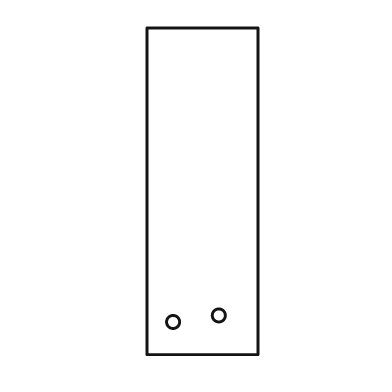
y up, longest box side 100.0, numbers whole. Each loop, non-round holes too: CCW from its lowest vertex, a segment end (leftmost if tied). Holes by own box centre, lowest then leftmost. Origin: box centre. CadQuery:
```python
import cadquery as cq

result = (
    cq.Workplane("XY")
    .moveTo(-17.0, -50.0)
    .lineTo(17.0, -50.0)
    .lineTo(17.0, 50.0)
    .lineTo(-17.0, 50.0)
    .close()
    .moveTo(-9.0, -40.0)
    .circle(2.0)
    .moveTo(5.0, -38.0)
    .circle(2.0)
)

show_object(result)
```